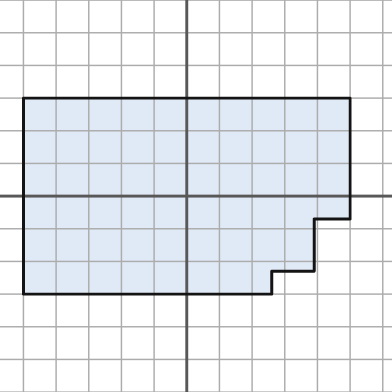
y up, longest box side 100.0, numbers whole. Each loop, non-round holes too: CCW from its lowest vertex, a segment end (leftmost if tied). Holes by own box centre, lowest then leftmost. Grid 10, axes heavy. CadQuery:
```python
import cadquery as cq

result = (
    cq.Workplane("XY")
    .moveTo(-50.0, -30.0)
    .lineTo(26.0, -30.0)
    .lineTo(26.0, -23.0)
    .lineTo(39.0, -23.0)
    .lineTo(39.0, -7.0)
    .lineTo(50.0, -7.0)
    .lineTo(50.0, 30.0)
    .lineTo(-50.0, 30.0)
    .close()
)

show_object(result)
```